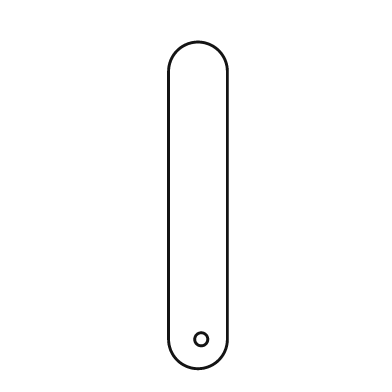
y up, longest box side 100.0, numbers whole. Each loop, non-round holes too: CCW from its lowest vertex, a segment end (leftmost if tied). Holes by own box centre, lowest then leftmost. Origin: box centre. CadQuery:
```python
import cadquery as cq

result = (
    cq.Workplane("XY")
    .moveTo(-9.0, -41.0)
    .threePointArc((0.0, -50.0), (9.0, -41.0))
    .lineTo(9.0, 41.0)
    .threePointArc((0.0, 50.0), (-9.0, 41.0))
    .close()
    .moveTo(1.0, -41.0)
    .circle(2.0)
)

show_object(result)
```